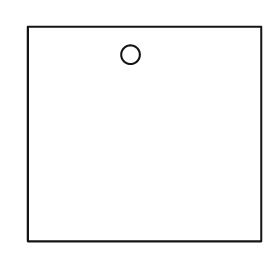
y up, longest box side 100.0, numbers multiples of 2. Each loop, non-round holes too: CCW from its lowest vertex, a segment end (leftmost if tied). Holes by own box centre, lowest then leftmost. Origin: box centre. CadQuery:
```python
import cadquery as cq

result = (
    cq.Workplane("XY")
    .moveTo(-50.0, -46.0)
    .lineTo(50.0, -46.0)
    .lineTo(50.0, 46.0)
    .lineTo(-50.0, 46.0)
    .close()
    .moveTo(-6.0, 34.0)
    .circle(4.0)
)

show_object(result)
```